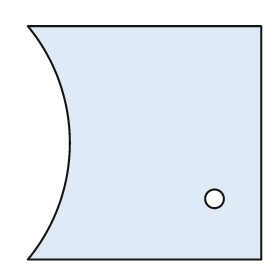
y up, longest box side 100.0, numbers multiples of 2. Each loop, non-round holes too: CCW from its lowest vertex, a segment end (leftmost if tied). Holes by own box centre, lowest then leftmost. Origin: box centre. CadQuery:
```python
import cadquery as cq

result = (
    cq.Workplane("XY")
    .moveTo(-50.0, -50.0)
    .lineTo(50.0, -50.0)
    .lineTo(50.0, 50.0)
    .lineTo(-50.0, 50.0)
    .threePointArc((-32.0, 0.0), (-50.0, -50.0))
    .close()
    .moveTo(30.0, -24.0)
    .circle(4.0)
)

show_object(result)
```